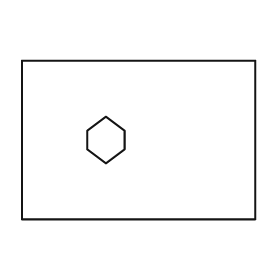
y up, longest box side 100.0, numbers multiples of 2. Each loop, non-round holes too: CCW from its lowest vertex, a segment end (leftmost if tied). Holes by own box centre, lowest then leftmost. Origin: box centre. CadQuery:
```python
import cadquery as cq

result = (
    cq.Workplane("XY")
    .moveTo(-50.0, -34.0)
    .lineTo(50.0, -34.0)
    .lineTo(50.0, 34.0)
    .lineTo(-50.0, 34.0)
    .close()
    .moveTo(-14.0, -10.0)
    .lineTo(-6.0, -4.0)
    .lineTo(-6.0, 4.0)
    .lineTo(-14.0, 10.0)
    .lineTo(-22.0, 4.0)
    .lineTo(-22.0, -4.0)
    .close()
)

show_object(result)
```